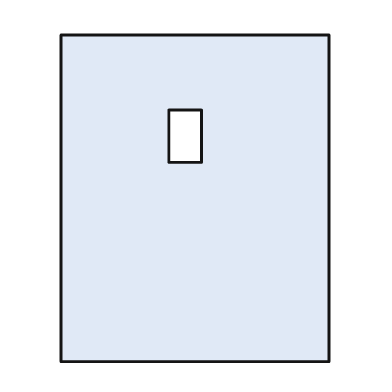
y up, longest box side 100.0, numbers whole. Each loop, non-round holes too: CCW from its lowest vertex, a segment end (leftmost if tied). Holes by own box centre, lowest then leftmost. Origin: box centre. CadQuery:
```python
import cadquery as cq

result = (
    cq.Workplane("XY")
    .moveTo(-41.0, -50.0)
    .lineTo(41.0, -50.0)
    .lineTo(41.0, 50.0)
    .lineTo(-41.0, 50.0)
    .close()
    .moveTo(-8.0, 11.0)
    .lineTo(2.0, 11.0)
    .lineTo(2.0, 27.0)
    .lineTo(-8.0, 27.0)
    .close()
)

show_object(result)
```